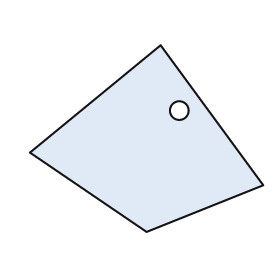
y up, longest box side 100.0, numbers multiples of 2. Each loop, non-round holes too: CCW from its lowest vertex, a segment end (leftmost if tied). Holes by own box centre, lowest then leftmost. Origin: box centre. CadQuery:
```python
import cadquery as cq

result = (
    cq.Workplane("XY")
    .moveTo(0.0, -40.0)
    .lineTo(50.0, -20.0)
    .lineTo(6.0, 40.0)
    .lineTo(-50.0, -6.0)
    .close()
    .moveTo(14.0, 12.0)
    .circle(4.0)
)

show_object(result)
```